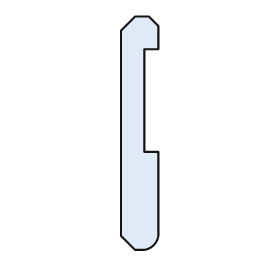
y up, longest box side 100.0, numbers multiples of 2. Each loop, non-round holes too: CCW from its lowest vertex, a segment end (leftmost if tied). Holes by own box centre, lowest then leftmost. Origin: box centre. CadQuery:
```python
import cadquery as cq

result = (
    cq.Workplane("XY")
    .moveTo(-2.0, -50.0)
    .lineTo(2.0, -50.0)
    .threePointArc((6.0, -48.0), (8.0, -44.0))
    .lineTo(8.0, -8.0)
    .lineTo(2.0, -8.0)
    .lineTo(2.0, 36.0)
    .lineTo(8.0, 36.0)
    .lineTo(8.0, 46.0)
    .lineTo(4.0, 50.0)
    .lineTo(-2.0, 50.0)
    .lineTo(-8.0, 44.0)
    .lineTo(-8.0, -44.0)
    .close()
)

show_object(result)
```